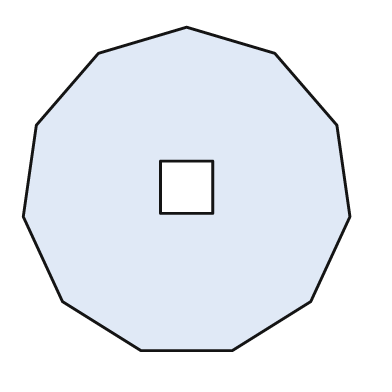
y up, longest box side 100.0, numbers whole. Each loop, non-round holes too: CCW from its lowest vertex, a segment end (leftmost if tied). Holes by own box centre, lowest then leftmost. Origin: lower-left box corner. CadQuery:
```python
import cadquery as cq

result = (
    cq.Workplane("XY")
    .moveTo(36.0, 0.0)
    .lineTo(64.0, 0.0)
    .lineTo(88.0, 15.0)
    .lineTo(100.0, 41.0)
    .lineTo(96.0, 69.0)
    .lineTo(77.0, 91.0)
    .lineTo(50.0, 99.0)
    .lineTo(23.0, 91.0)
    .lineTo(4.0, 69.0)
    .lineTo(0.0, 41.0)
    .lineTo(12.0, 15.0)
    .close()
    .moveTo(42.0, 42.0)
    .lineTo(58.0, 42.0)
    .lineTo(58.0, 58.0)
    .lineTo(42.0, 58.0)
    .close()
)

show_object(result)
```